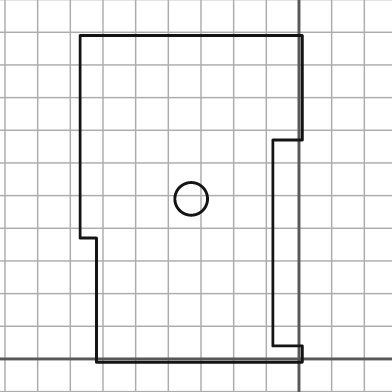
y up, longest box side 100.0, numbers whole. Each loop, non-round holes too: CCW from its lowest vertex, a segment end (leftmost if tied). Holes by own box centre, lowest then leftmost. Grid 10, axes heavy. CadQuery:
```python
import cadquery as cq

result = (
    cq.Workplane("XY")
    .moveTo(-62.0, -1.0)
    .lineTo(1.0, -1.0)
    .lineTo(1.0, 4.0)
    .lineTo(-8.0, 4.0)
    .lineTo(-8.0, 67.0)
    .lineTo(1.0, 67.0)
    .lineTo(1.0, 99.0)
    .lineTo(-67.0, 99.0)
    .lineTo(-67.0, 37.0)
    .lineTo(-62.0, 37.0)
    .close()
    .moveTo(-33.0, 49.0)
    .circle(5.0)
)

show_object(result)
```